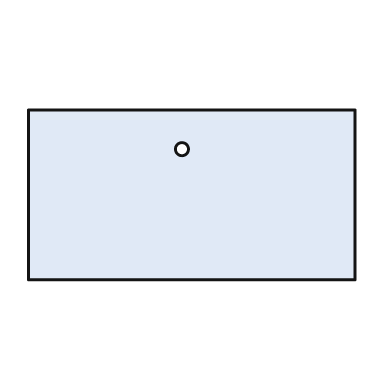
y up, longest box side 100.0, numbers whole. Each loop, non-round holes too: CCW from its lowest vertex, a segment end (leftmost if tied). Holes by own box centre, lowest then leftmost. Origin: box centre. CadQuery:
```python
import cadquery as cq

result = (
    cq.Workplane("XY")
    .moveTo(-50.0, -26.0)
    .lineTo(50.0, -26.0)
    .lineTo(50.0, 26.0)
    .lineTo(-50.0, 26.0)
    .close()
    .moveTo(-3.0, 14.0)
    .circle(2.0)
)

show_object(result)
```